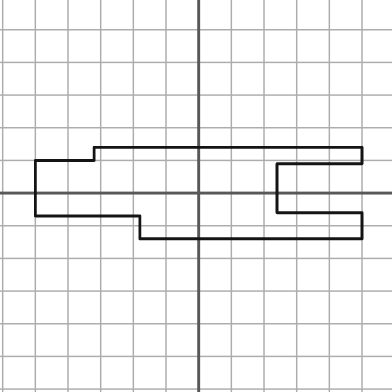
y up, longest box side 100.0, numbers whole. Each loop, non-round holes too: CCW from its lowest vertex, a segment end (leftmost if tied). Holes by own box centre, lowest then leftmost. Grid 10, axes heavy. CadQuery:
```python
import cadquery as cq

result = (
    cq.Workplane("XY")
    .moveTo(-18.0, -14.0)
    .lineTo(50.0, -14.0)
    .lineTo(50.0, -6.0)
    .lineTo(24.0, -6.0)
    .lineTo(24.0, 9.0)
    .lineTo(50.0, 9.0)
    .lineTo(50.0, 14.0)
    .lineTo(-32.0, 14.0)
    .lineTo(-32.0, 10.0)
    .lineTo(-50.0, 10.0)
    .lineTo(-50.0, -7.0)
    .lineTo(-18.0, -7.0)
    .close()
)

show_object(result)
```